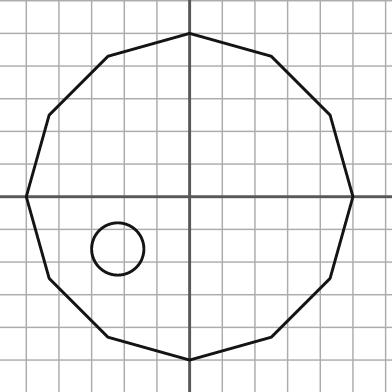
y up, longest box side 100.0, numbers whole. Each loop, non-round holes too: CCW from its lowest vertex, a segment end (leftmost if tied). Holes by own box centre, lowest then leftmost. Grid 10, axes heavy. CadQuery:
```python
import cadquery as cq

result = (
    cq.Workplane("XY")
    .moveTo(0.0, -50.0)
    .lineTo(25.0, -43.0)
    .lineTo(43.0, -25.0)
    .lineTo(50.0, 0.0)
    .lineTo(43.0, 25.0)
    .lineTo(25.0, 43.0)
    .lineTo(0.0, 50.0)
    .lineTo(-25.0, 43.0)
    .lineTo(-43.0, 25.0)
    .lineTo(-50.0, 0.0)
    .lineTo(-43.0, -25.0)
    .lineTo(-25.0, -43.0)
    .close()
    .moveTo(-22.0, -16.0)
    .circle(8.0)
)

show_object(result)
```